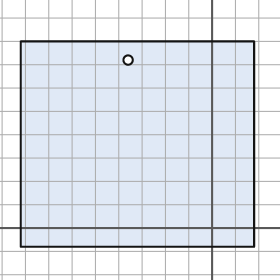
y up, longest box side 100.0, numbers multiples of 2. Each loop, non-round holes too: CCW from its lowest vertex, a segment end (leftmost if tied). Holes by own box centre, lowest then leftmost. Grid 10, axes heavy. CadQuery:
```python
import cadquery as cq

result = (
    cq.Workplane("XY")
    .moveTo(-82.0, -8.0)
    .lineTo(18.0, -8.0)
    .lineTo(18.0, 80.0)
    .lineTo(-82.0, 80.0)
    .close()
    .moveTo(-36.0, 72.0)
    .circle(2.0)
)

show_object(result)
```